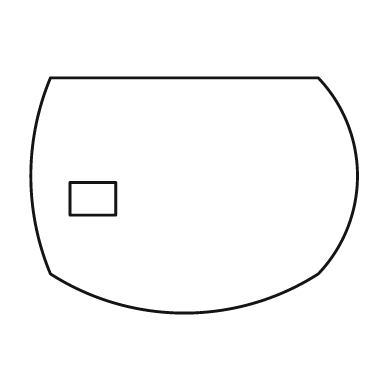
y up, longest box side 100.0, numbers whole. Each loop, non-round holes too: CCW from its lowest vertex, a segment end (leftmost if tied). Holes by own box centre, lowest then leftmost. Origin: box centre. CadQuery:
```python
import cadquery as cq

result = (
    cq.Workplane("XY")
    .moveTo(-44.0, -24.0)
    .threePointArc((-3.0, -36.0), (38.0, -24.0))
    .threePointArc((50.0, 6.0), (38.0, 36.0))
    .lineTo(-44.0, 36.0)
    .threePointArc((-50.0, 6.0), (-44.0, -24.0))
    .close()
    .moveTo(-38.0, -6.0)
    .lineTo(-24.0, -6.0)
    .lineTo(-24.0, 4.0)
    .lineTo(-38.0, 4.0)
    .close()
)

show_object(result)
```